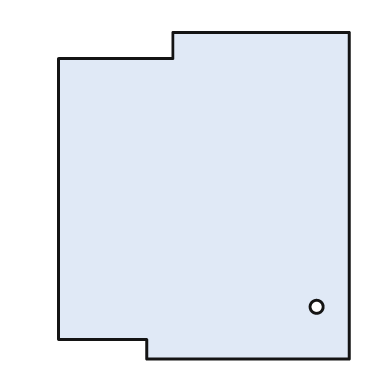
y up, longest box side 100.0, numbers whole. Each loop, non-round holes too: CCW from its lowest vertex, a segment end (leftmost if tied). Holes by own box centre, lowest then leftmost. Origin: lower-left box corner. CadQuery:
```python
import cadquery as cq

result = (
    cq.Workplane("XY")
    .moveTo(27.0, 0.0)
    .lineTo(89.0, 0.0)
    .lineTo(89.0, 100.0)
    .lineTo(35.0, 100.0)
    .lineTo(35.0, 92.0)
    .lineTo(0.0, 92.0)
    .lineTo(0.0, 6.0)
    .lineTo(27.0, 6.0)
    .close()
    .moveTo(79.0, 16.0)
    .circle(2.0)
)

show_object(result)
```